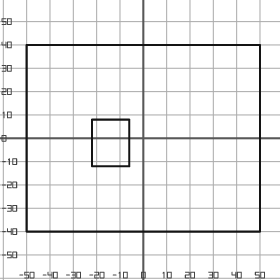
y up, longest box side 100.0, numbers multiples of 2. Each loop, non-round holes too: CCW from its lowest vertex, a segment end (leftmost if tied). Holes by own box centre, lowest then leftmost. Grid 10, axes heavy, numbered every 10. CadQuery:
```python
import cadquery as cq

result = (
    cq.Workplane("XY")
    .moveTo(-50.0, -40.0)
    .lineTo(50.0, -40.0)
    .lineTo(50.0, 40.0)
    .lineTo(-50.0, 40.0)
    .close()
    .moveTo(-22.0, -12.0)
    .lineTo(-6.0, -12.0)
    .lineTo(-6.0, 8.0)
    .lineTo(-22.0, 8.0)
    .close()
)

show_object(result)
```